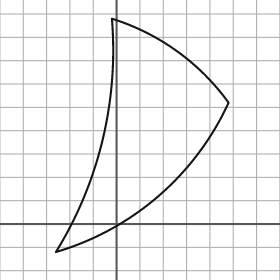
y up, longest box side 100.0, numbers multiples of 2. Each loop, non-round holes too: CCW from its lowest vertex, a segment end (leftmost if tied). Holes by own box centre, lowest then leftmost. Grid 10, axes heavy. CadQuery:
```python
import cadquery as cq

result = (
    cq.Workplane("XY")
    .moveTo(-26.0, -12.0)
    .threePointArc((18.0, 12.0), (48.0, 52.0))
    .threePointArc((26.0, 74.0), (-2.0, 88.0))
    .threePointArc((-6.0, 36.0), (-26.0, -12.0))
    .close()
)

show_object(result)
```